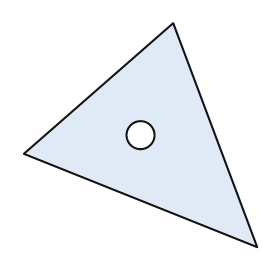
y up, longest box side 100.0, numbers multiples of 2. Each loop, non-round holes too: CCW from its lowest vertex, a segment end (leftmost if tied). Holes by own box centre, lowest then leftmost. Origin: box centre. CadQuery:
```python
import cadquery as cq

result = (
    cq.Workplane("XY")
    .moveTo(50.0, -48.0)
    .lineTo(14.0, 48.0)
    .lineTo(-50.0, -8.0)
    .close()
    .moveTo(0.0, 0.0)
    .circle(6.0)
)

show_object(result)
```